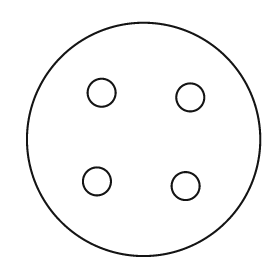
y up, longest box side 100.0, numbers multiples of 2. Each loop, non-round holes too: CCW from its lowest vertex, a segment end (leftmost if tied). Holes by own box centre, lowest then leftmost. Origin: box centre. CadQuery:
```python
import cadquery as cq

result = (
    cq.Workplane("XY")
    .moveTo(0.0, 0.0)
    .circle(50.0)
    .moveTo(18.0, -20.0)
    .circle(6.0)
    .moveTo(-20.0, -18.0)
    .circle(6.0)
    .moveTo(20.0, 18.0)
    .circle(6.0)
    .moveTo(-18.0, 20.0)
    .circle(6.0)
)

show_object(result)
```